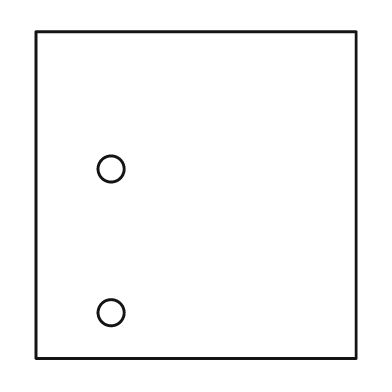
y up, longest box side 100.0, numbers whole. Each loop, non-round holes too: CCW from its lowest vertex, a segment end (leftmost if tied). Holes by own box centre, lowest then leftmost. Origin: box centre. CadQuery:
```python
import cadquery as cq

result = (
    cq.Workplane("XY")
    .moveTo(-49.0, -50.0)
    .lineTo(49.0, -50.0)
    .lineTo(49.0, 50.0)
    .lineTo(-49.0, 50.0)
    .close()
    .moveTo(-26.0, -36.0)
    .circle(4.0)
    .moveTo(-26.0, 8.0)
    .circle(4.0)
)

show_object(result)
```